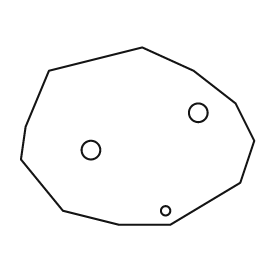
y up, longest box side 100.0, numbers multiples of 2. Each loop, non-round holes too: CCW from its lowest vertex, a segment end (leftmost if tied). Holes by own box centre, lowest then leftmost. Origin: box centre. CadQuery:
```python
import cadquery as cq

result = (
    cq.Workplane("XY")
    .moveTo(-8.0, -38.0)
    .lineTo(14.0, -38.0)
    .lineTo(44.0, -20.0)
    .lineTo(50.0, -2.0)
    .lineTo(42.0, 14.0)
    .lineTo(24.0, 28.0)
    .lineTo(2.0, 38.0)
    .lineTo(-38.0, 28.0)
    .lineTo(-48.0, 4.0)
    .lineTo(-50.0, -10.0)
    .lineTo(-32.0, -32.0)
    .close()
    .moveTo(12.0, -32.0)
    .circle(2.0)
    .moveTo(-20.0, -6.0)
    .circle(4.0)
    .moveTo(26.0, 10.0)
    .circle(4.0)
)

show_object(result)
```